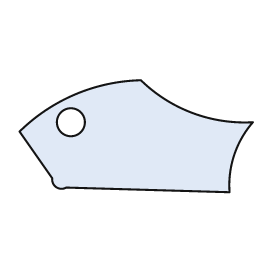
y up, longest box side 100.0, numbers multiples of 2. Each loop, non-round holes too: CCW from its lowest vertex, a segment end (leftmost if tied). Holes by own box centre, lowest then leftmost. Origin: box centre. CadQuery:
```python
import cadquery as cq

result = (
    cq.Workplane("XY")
    .moveTo(40.0, -24.0)
    .threePointArc((42.0, -8.0), (50.0, 6.0))
    .threePointArc((24.0, 10.0), (2.0, 24.0))
    .threePointArc((-26.0, 18.0), (-50.0, 2.0))
    .lineTo(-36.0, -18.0)
    .threePointArc((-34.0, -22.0), (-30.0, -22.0))
    .close()
    .moveTo(-28.0, 6.0)
    .circle(6.0)
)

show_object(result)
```